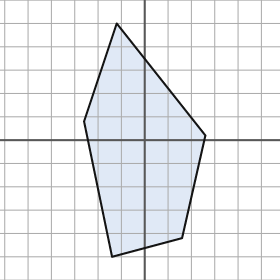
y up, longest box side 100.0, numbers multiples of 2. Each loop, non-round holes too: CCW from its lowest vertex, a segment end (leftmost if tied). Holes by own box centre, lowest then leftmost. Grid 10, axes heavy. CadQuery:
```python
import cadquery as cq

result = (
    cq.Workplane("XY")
    .moveTo(-14.0, -50.0)
    .lineTo(16.0, -42.0)
    .lineTo(26.0, 2.0)
    .lineTo(-12.0, 50.0)
    .lineTo(-26.0, 8.0)
    .close()
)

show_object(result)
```